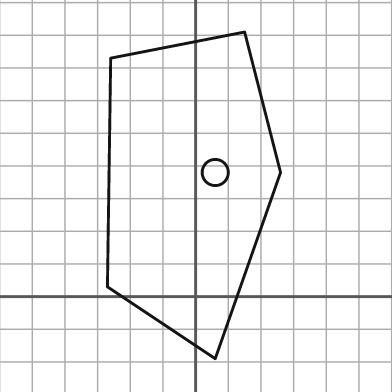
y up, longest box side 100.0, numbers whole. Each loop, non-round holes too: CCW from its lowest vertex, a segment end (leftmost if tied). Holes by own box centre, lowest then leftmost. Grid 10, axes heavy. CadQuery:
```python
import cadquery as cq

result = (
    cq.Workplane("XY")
    .moveTo(6.0, -19.0)
    .lineTo(26.0, 38.0)
    .lineTo(15.0, 81.0)
    .lineTo(-26.0, 73.0)
    .lineTo(-27.0, 3.0)
    .close()
    .moveTo(6.0, 38.0)
    .circle(4.0)
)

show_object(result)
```